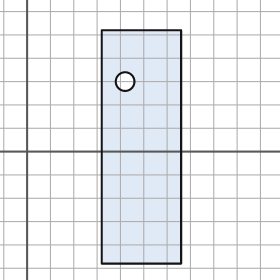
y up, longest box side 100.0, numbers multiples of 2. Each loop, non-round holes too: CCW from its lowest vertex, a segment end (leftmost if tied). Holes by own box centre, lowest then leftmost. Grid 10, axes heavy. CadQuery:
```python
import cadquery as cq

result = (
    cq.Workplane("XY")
    .moveTo(32.0, -48.0)
    .lineTo(66.0, -48.0)
    .lineTo(66.0, 52.0)
    .lineTo(32.0, 52.0)
    .close()
    .moveTo(42.0, 30.0)
    .circle(4.0)
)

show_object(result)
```